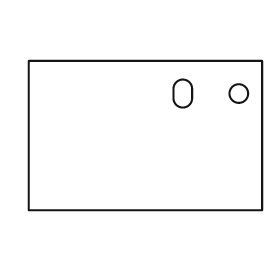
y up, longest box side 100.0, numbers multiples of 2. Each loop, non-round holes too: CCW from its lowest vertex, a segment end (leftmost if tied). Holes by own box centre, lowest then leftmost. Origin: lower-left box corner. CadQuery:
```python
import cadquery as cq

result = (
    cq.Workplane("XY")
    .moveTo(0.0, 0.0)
    .lineTo(100.0, 0.0)
    .lineTo(100.0, 64.0)
    .lineTo(0.0, 64.0)
    .close()
    .moveTo(62.0, 48.0)
    .threePointArc((66.0, 44.0), (70.0, 48.0))
    .lineTo(70.0, 52.0)
    .threePointArc((66.0, 56.0), (62.0, 52.0))
    .close()
    .moveTo(90.0, 50.0)
    .circle(4.0)
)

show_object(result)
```